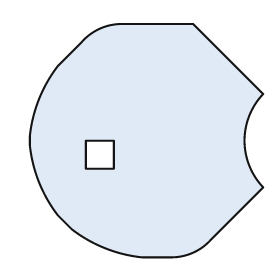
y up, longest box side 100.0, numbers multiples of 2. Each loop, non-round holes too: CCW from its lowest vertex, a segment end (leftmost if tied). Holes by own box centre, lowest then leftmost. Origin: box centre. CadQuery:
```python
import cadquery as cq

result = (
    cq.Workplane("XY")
    .moveTo(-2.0, -50.0)
    .lineTo(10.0, -50.0)
    .threePointArc((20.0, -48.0), (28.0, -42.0))
    .lineTo(50.0, -20.0)
    .threePointArc((42.0, 0.0), (50.0, 20.0))
    .lineTo(20.0, 50.0)
    .lineTo(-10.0, 50.0)
    .threePointArc((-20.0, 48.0), (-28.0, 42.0))
    .lineTo(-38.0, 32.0)
    .threePointArc((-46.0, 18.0), (-50.0, 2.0))
    .lineTo(-50.0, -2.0)
    .threePointArc((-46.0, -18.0), (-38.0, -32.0))
    .lineTo(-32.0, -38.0)
    .threePointArc((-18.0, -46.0), (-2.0, -50.0))
    .close()
    .moveTo(-26.0, -12.0)
    .lineTo(-14.0, -12.0)
    .lineTo(-14.0, 0.0)
    .lineTo(-26.0, 0.0)
    .close()
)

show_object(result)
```